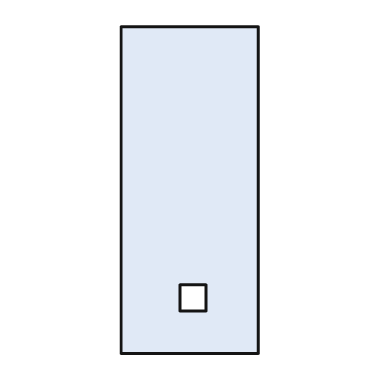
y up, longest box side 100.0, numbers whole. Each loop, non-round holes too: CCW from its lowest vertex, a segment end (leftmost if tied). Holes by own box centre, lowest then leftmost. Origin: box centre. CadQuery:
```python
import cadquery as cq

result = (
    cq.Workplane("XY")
    .moveTo(-21.0, -50.0)
    .lineTo(21.0, -50.0)
    .lineTo(21.0, 50.0)
    .lineTo(-21.0, 50.0)
    .close()
    .moveTo(-3.0, -37.0)
    .lineTo(5.0, -37.0)
    .lineTo(5.0, -29.0)
    .lineTo(-3.0, -29.0)
    .close()
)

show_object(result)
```